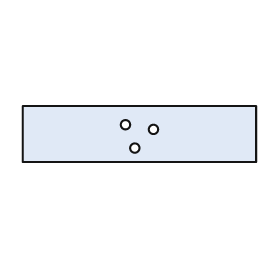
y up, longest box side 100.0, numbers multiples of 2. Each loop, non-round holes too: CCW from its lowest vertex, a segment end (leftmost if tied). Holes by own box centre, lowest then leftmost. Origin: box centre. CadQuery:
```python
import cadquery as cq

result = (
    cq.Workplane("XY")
    .moveTo(-50.0, -12.0)
    .lineTo(50.0, -12.0)
    .lineTo(50.0, 12.0)
    .lineTo(-50.0, 12.0)
    .close()
    .moveTo(-2.0, -6.0)
    .circle(2.0)
    .moveTo(6.0, 2.0)
    .circle(2.0)
    .moveTo(-6.0, 4.0)
    .circle(2.0)
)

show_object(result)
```